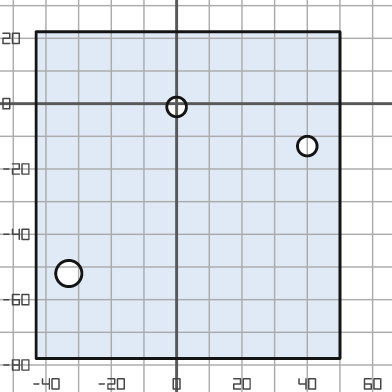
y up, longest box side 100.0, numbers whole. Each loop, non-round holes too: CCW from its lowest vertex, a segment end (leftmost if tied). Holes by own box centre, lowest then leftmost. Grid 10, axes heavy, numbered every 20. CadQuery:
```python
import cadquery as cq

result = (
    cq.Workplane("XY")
    .moveTo(-43.0, -78.0)
    .lineTo(50.0, -78.0)
    .lineTo(50.0, 22.0)
    .lineTo(-43.0, 22.0)
    .close()
    .moveTo(-33.0, -52.0)
    .circle(4.0)
    .moveTo(40.0, -13.0)
    .circle(3.0)
    .moveTo(0.0, -1.0)
    .circle(3.0)
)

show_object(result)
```